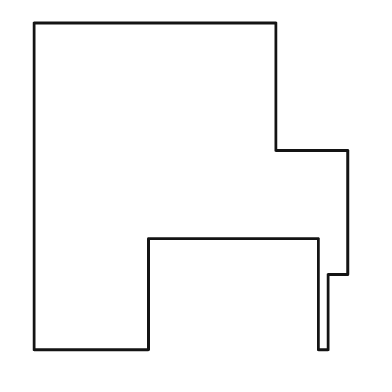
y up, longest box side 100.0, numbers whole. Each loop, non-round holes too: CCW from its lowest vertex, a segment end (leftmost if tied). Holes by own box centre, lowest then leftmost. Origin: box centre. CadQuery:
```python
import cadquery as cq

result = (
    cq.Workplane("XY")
    .moveTo(-48.0, -50.0)
    .lineTo(-13.0, -50.0)
    .lineTo(-13.0, -16.0)
    .lineTo(39.0, -16.0)
    .lineTo(39.0, -50.0)
    .lineTo(42.0, -50.0)
    .lineTo(42.0, -27.0)
    .lineTo(48.0, -27.0)
    .lineTo(48.0, 11.0)
    .lineTo(26.0, 11.0)
    .lineTo(26.0, 50.0)
    .lineTo(-48.0, 50.0)
    .close()
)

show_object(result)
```